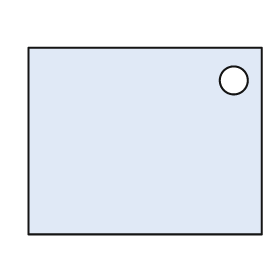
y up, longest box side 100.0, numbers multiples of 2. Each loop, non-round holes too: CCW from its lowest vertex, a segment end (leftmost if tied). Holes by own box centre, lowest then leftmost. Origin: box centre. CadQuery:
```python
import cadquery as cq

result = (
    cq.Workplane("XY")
    .moveTo(-50.0, -40.0)
    .lineTo(50.0, -40.0)
    .lineTo(50.0, 40.0)
    .lineTo(-50.0, 40.0)
    .close()
    .moveTo(38.0, 26.0)
    .circle(6.0)
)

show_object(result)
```